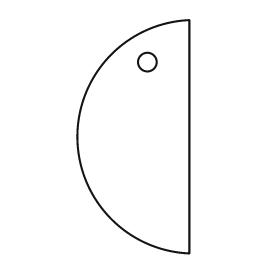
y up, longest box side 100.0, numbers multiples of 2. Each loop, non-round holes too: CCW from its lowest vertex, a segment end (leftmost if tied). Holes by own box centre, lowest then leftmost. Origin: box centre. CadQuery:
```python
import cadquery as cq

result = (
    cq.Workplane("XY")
    .moveTo(24.0, -50.0)
    .lineTo(24.0, 50.0)
    .threePointArc((-24.0, 0.0), (24.0, -50.0))
    .close()
    .moveTo(6.0, 32.0)
    .circle(4.0)
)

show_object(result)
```